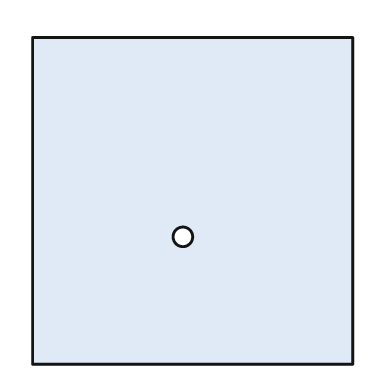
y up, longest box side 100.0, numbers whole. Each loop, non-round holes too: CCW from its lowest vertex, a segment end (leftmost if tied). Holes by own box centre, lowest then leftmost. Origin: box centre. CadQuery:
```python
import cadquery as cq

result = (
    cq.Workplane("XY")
    .moveTo(-49.0, -50.0)
    .lineTo(49.0, -50.0)
    .lineTo(49.0, 50.0)
    .lineTo(-49.0, 50.0)
    .close()
    .moveTo(-3.0, -11.0)
    .circle(3.0)
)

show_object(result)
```